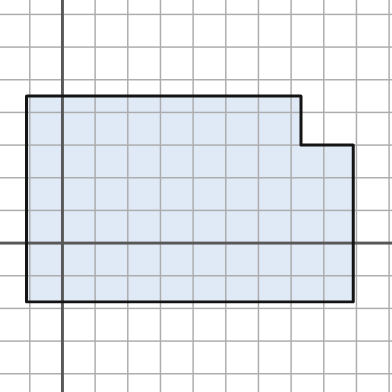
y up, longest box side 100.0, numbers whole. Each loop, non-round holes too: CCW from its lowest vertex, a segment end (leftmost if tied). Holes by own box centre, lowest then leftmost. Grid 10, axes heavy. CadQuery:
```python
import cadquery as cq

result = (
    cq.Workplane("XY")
    .moveTo(-11.0, -18.0)
    .lineTo(89.0, -18.0)
    .lineTo(89.0, 30.0)
    .lineTo(73.0, 30.0)
    .lineTo(73.0, 45.0)
    .lineTo(-11.0, 45.0)
    .close()
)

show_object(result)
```